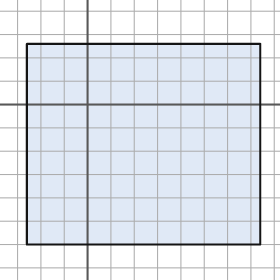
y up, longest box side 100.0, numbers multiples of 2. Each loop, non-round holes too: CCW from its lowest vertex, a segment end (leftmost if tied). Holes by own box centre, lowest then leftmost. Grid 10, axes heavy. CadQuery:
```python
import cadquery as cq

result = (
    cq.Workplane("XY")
    .moveTo(-26.0, -60.0)
    .lineTo(74.0, -60.0)
    .lineTo(74.0, 26.0)
    .lineTo(-26.0, 26.0)
    .close()
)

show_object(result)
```